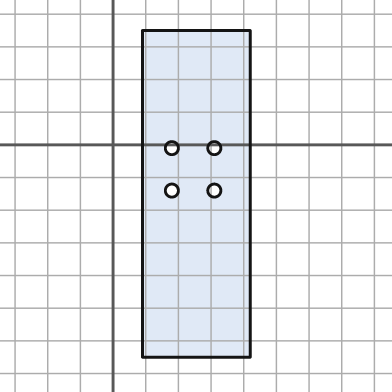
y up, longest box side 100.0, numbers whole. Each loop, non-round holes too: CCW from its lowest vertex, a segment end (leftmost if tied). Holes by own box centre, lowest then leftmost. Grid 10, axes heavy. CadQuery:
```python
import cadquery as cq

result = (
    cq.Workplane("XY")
    .moveTo(9.0, -65.0)
    .lineTo(42.0, -65.0)
    .lineTo(42.0, 35.0)
    .lineTo(9.0, 35.0)
    .close()
    .moveTo(18.0, -14.0)
    .circle(2.0)
    .moveTo(31.0, -14.0)
    .circle(2.0)
    .moveTo(18.0, -1.0)
    .circle(2.0)
    .moveTo(31.0, -1.0)
    .circle(2.0)
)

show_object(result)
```